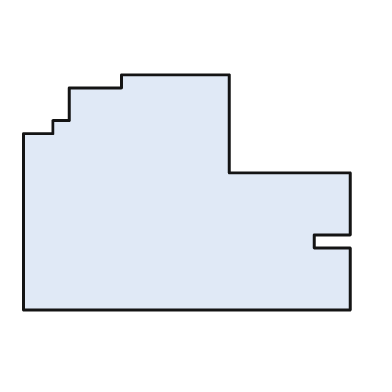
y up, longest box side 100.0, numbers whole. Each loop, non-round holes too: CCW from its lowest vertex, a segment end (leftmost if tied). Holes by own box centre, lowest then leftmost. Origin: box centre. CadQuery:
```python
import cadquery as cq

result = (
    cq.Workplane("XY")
    .moveTo(-50.0, -36.0)
    .lineTo(50.0, -36.0)
    .lineTo(50.0, -17.0)
    .lineTo(39.0, -17.0)
    .lineTo(39.0, -13.0)
    .lineTo(50.0, -13.0)
    .lineTo(50.0, 6.0)
    .lineTo(13.0, 6.0)
    .lineTo(13.0, 36.0)
    .lineTo(-20.0, 36.0)
    .lineTo(-20.0, 32.0)
    .lineTo(-36.0, 32.0)
    .lineTo(-36.0, 22.0)
    .lineTo(-41.0, 22.0)
    .lineTo(-41.0, 18.0)
    .lineTo(-50.0, 18.0)
    .close()
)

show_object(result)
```